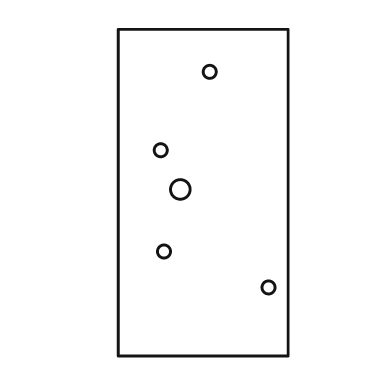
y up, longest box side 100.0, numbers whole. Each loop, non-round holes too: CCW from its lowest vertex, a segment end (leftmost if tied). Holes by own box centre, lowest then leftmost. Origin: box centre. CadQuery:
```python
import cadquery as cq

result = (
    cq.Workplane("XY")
    .moveTo(-26.0, -50.0)
    .lineTo(26.0, -50.0)
    .lineTo(26.0, 50.0)
    .lineTo(-26.0, 50.0)
    .close()
    .moveTo(20.0, -29.0)
    .circle(2.0)
    .moveTo(-12.0, -18.0)
    .circle(2.0)
    .moveTo(-7.0, 1.0)
    .circle(3.0)
    .moveTo(-13.0, 13.0)
    .circle(2.0)
    .moveTo(2.0, 37.0)
    .circle(2.0)
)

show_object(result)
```